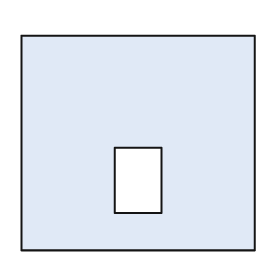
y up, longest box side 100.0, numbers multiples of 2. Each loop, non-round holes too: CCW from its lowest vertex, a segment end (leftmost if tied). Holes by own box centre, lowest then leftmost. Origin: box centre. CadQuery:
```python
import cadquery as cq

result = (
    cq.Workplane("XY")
    .moveTo(-50.0, -46.0)
    .lineTo(50.0, -46.0)
    .lineTo(50.0, 46.0)
    .lineTo(-50.0, 46.0)
    .close()
    .moveTo(-10.0, -30.0)
    .lineTo(10.0, -30.0)
    .lineTo(10.0, -2.0)
    .lineTo(-10.0, -2.0)
    .close()
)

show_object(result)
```